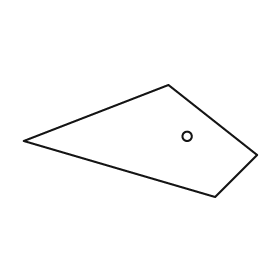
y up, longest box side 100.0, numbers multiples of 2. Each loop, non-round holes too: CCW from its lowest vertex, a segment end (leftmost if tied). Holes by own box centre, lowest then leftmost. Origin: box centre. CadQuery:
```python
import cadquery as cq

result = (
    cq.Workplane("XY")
    .moveTo(32.0, -24.0)
    .lineTo(50.0, -6.0)
    .lineTo(12.0, 24.0)
    .lineTo(-50.0, 0.0)
    .close()
    .moveTo(20.0, 2.0)
    .circle(2.0)
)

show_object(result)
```